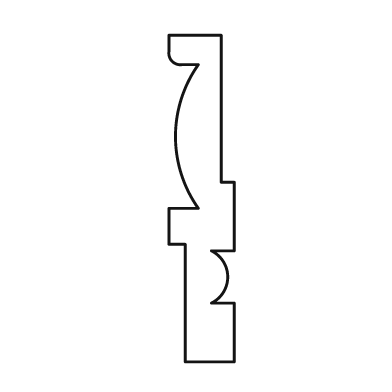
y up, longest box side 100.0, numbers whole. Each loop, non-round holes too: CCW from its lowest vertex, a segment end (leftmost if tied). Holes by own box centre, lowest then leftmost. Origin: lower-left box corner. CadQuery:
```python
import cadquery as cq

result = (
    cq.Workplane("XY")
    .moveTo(5.0, 0.0)
    .lineTo(20.0, 0.0)
    .lineTo(20.0, 18.0)
    .lineTo(13.0, 18.0)
    .threePointArc((18.0, 26.0), (13.0, 34.0))
    .lineTo(20.0, 34.0)
    .lineTo(20.0, 55.0)
    .lineTo(16.0, 55.0)
    .lineTo(16.0, 100.0)
    .lineTo(0.0, 100.0)
    .lineTo(0.0, 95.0)
    .threePointArc((1.0, 92.0), (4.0, 91.0))
    .lineTo(9.0, 91.0)
    .threePointArc((2.0, 69.0), (9.0, 47.0))
    .lineTo(0.0, 47.0)
    .lineTo(0.0, 36.0)
    .lineTo(5.0, 36.0)
    .close()
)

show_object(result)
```